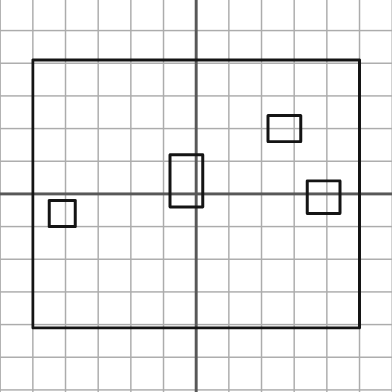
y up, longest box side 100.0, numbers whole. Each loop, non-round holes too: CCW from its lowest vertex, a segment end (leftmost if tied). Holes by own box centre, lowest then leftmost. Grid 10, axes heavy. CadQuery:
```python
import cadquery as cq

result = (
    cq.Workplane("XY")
    .moveTo(-50.0, -41.0)
    .lineTo(50.0, -41.0)
    .lineTo(50.0, 41.0)
    .lineTo(-50.0, 41.0)
    .close()
    .moveTo(-45.0, -10.0)
    .lineTo(-37.0, -10.0)
    .lineTo(-37.0, -2.0)
    .lineTo(-45.0, -2.0)
    .close()
    .moveTo(34.0, -6.0)
    .lineTo(44.0, -6.0)
    .lineTo(44.0, 4.0)
    .lineTo(34.0, 4.0)
    .close()
    .moveTo(-8.0, -4.0)
    .lineTo(2.0, -4.0)
    .lineTo(2.0, 12.0)
    .lineTo(-8.0, 12.0)
    .close()
    .moveTo(22.0, 16.0)
    .lineTo(32.0, 16.0)
    .lineTo(32.0, 24.0)
    .lineTo(22.0, 24.0)
    .close()
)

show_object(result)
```